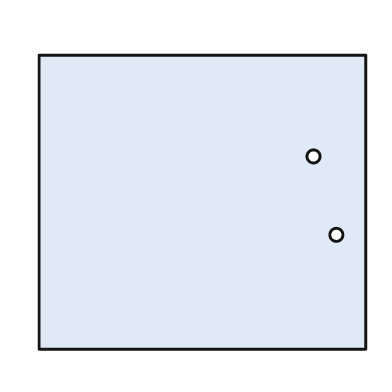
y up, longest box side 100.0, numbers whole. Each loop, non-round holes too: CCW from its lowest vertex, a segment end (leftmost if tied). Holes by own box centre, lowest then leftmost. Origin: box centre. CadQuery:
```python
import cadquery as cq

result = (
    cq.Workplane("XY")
    .moveTo(-50.0, -45.0)
    .lineTo(50.0, -45.0)
    .lineTo(50.0, 45.0)
    .lineTo(-50.0, 45.0)
    .close()
    .moveTo(41.0, -10.0)
    .circle(2.0)
    .moveTo(34.0, 14.0)
    .circle(2.0)
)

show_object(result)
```